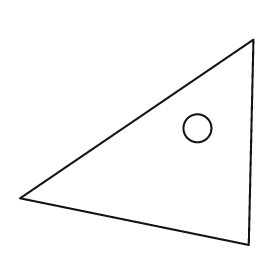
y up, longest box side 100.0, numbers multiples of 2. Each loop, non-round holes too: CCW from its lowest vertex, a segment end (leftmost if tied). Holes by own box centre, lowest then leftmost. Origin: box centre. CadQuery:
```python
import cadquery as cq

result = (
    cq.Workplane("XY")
    .moveTo(48.0, -44.0)
    .lineTo(50.0, 44.0)
    .lineTo(-50.0, -24.0)
    .close()
    .moveTo(26.0, 6.0)
    .circle(6.0)
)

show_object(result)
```